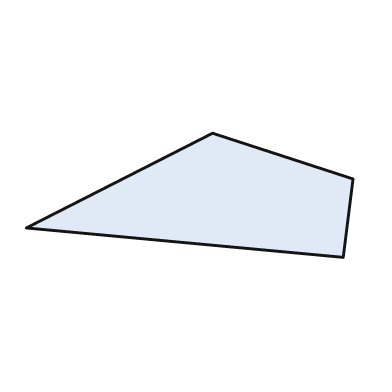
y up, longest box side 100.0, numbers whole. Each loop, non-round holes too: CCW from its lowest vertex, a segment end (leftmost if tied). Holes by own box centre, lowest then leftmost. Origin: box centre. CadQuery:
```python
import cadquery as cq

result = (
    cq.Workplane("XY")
    .moveTo(47.0, -19.0)
    .lineTo(50.0, 5.0)
    .lineTo(7.0, 19.0)
    .lineTo(-50.0, -10.0)
    .close()
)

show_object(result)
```